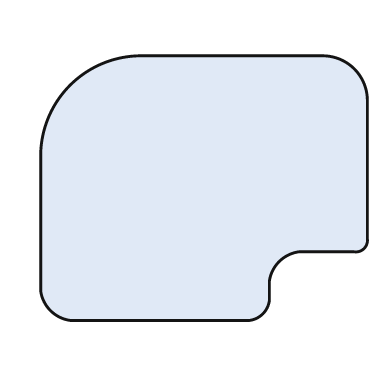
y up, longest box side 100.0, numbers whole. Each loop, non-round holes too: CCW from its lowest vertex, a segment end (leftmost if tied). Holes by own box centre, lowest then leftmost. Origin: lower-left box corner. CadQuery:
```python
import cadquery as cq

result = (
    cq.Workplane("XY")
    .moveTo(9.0, 0.0)
    .lineTo(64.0, 0.0)
    .threePointArc((68.0, 2.0), (70.0, 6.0))
    .lineTo(70.0, 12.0)
    .threePointArc((73.0, 18.0), (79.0, 21.0))
    .lineTo(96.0, 21.0)
    .threePointArc((99.0, 22.0), (100.0, 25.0))
    .lineTo(100.0, 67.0)
    .threePointArc((96.0, 77.0), (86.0, 81.0))
    .lineTo(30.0, 81.0)
    .threePointArc((9.0, 72.0), (0.0, 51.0))
    .lineTo(0.0, 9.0)
    .threePointArc((3.0, 3.0), (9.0, 0.0))
    .close()
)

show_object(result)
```